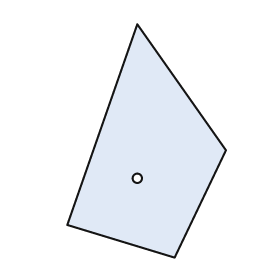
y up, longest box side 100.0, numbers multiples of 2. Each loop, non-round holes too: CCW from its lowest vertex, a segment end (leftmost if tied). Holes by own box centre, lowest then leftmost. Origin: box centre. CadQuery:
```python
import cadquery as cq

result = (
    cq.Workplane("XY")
    .moveTo(12.0, -50.0)
    .lineTo(34.0, -4.0)
    .lineTo(-4.0, 50.0)
    .lineTo(-34.0, -36.0)
    .close()
    .moveTo(-4.0, -16.0)
    .circle(2.0)
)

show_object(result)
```